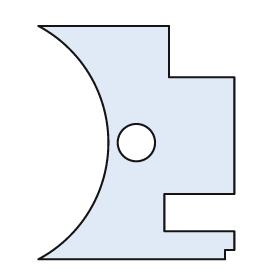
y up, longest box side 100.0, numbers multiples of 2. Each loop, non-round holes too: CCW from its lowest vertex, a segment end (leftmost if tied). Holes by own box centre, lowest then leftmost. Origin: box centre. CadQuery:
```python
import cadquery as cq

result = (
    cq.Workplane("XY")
    .moveTo(-42.0, -50.0)
    .lineTo(38.0, -50.0)
    .lineTo(38.0, -46.0)
    .lineTo(42.0, -46.0)
    .lineTo(42.0, -38.0)
    .lineTo(12.0, -38.0)
    .lineTo(12.0, -22.0)
    .lineTo(42.0, -22.0)
    .lineTo(42.0, 28.0)
    .lineTo(14.0, 28.0)
    .lineTo(14.0, 50.0)
    .lineTo(-42.0, 50.0)
    .threePointArc((-12.0, 0.0), (-42.0, -50.0))
    .close()
    .moveTo(0.0, 0.0)
    .circle(8.0)
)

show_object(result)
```